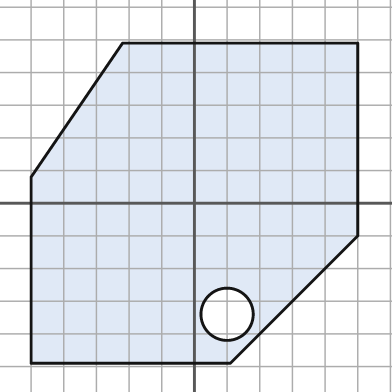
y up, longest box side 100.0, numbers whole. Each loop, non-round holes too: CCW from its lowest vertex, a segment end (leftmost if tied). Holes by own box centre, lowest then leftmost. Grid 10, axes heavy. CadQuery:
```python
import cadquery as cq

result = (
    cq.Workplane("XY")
    .moveTo(-50.0, -49.0)
    .lineTo(11.0, -49.0)
    .lineTo(50.0, -10.0)
    .lineTo(50.0, 49.0)
    .lineTo(-22.0, 49.0)
    .lineTo(-50.0, 8.0)
    .close()
    .moveTo(10.0, -34.0)
    .circle(8.0)
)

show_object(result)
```